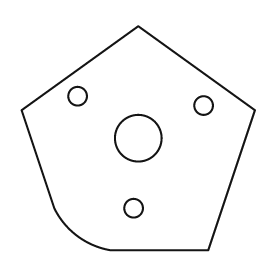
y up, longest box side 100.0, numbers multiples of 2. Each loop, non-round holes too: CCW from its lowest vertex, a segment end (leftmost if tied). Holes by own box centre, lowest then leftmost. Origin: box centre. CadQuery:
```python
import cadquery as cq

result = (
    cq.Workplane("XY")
    .moveTo(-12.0, -48.0)
    .lineTo(30.0, -48.0)
    .lineTo(50.0, 12.0)
    .lineTo(0.0, 48.0)
    .lineTo(-50.0, 12.0)
    .lineTo(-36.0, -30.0)
    .threePointArc((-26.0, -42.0), (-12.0, -48.0))
    .close()
    .moveTo(-2.0, -30.0)
    .circle(4.0)
    .moveTo(0.0, 0.0)
    .circle(10.0)
    .moveTo(28.0, 14.0)
    .circle(4.0)
    .moveTo(-26.0, 18.0)
    .circle(4.0)
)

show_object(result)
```